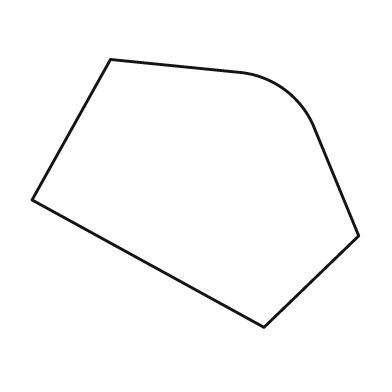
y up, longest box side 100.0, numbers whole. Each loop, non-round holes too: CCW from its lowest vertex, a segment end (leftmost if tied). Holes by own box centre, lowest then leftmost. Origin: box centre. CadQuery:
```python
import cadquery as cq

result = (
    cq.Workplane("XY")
    .moveTo(21.0, -41.0)
    .lineTo(50.0, -13.0)
    .lineTo(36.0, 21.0)
    .threePointArc((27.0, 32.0), (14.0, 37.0))
    .lineTo(-26.0, 41.0)
    .lineTo(-50.0, -2.0)
    .close()
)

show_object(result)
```